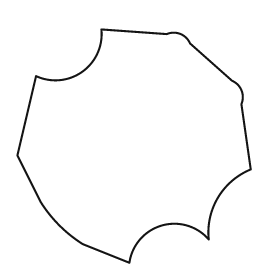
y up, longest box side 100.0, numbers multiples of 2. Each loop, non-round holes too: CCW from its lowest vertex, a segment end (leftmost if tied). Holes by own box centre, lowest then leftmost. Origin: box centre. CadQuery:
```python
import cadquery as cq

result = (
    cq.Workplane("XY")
    .moveTo(-2.0, -50.0)
    .threePointArc((12.0, -34.0), (32.0, -40.0))
    .threePointArc((36.0, -22.0), (50.0, -10.0))
    .lineTo(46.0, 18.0)
    .threePointArc((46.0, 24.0), (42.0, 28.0))
    .lineTo(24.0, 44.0)
    .threePointArc((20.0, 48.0), (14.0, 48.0))
    .lineTo(-14.0, 50.0)
    .threePointArc((-22.0, 32.0), (-42.0, 30.0))
    .lineTo(-50.0, -4.0)
    .lineTo(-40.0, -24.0)
    .threePointArc((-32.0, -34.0), (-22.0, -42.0))
    .close()
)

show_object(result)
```